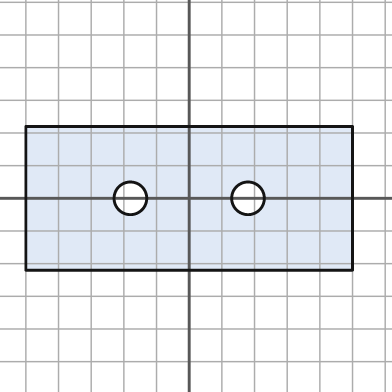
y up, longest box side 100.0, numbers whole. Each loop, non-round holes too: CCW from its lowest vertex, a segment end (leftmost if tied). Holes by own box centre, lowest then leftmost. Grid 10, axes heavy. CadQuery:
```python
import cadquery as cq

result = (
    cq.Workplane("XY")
    .moveTo(-50.0, -22.0)
    .lineTo(50.0, -22.0)
    .lineTo(50.0, 22.0)
    .lineTo(-50.0, 22.0)
    .close()
    .moveTo(-18.0, 0.0)
    .circle(5.0)
    .moveTo(18.0, 0.0)
    .circle(5.0)
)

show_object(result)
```